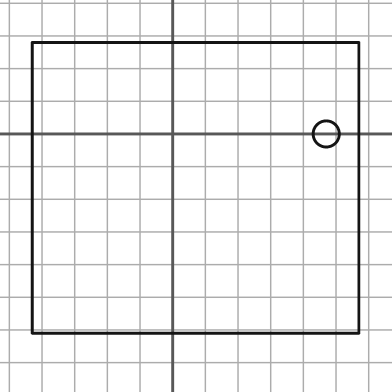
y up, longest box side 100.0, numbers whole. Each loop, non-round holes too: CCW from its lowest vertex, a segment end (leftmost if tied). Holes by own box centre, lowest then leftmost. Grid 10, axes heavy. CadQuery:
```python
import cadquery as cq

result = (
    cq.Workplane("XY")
    .moveTo(-43.0, -61.0)
    .lineTo(57.0, -61.0)
    .lineTo(57.0, 28.0)
    .lineTo(-43.0, 28.0)
    .close()
    .moveTo(47.0, 0.0)
    .circle(4.0)
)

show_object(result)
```